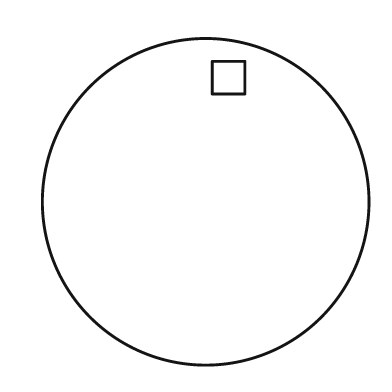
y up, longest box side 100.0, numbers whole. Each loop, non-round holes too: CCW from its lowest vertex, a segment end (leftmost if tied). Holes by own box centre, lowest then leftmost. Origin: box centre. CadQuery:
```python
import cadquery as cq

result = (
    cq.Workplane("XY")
    .moveTo(0.0, 0.0)
    .circle(50.0)
    .moveTo(2.0, 33.0)
    .lineTo(12.0, 33.0)
    .lineTo(12.0, 43.0)
    .lineTo(2.0, 43.0)
    .close()
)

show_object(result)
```